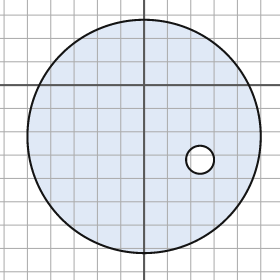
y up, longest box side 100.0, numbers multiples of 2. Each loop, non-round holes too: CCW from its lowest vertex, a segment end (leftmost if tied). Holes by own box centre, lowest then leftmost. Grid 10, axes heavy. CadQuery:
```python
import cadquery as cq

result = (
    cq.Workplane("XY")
    .moveTo(0.0, -22.0)
    .circle(50.0)
    .moveTo(24.0, -32.0)
    .circle(6.0)
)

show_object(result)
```